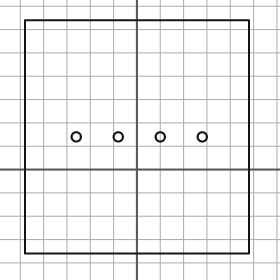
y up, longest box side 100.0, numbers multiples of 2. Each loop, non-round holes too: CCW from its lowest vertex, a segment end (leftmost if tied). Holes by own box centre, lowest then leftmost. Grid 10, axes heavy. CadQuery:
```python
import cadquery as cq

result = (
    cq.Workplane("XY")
    .moveTo(-48.0, -36.0)
    .lineTo(48.0, -36.0)
    .lineTo(48.0, 64.0)
    .lineTo(-48.0, 64.0)
    .close()
    .moveTo(-26.0, 14.0)
    .circle(2.0)
    .moveTo(-8.0, 14.0)
    .circle(2.0)
    .moveTo(10.0, 14.0)
    .circle(2.0)
    .moveTo(28.0, 14.0)
    .circle(2.0)
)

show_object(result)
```